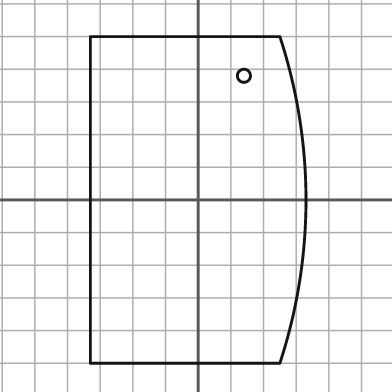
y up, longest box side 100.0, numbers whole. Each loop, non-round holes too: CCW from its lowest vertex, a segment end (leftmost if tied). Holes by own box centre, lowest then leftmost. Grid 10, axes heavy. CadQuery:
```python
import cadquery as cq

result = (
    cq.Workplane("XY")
    .moveTo(-33.0, -50.0)
    .lineTo(25.0, -50.0)
    .threePointArc((33.0, 0.0), (25.0, 50.0))
    .lineTo(-33.0, 50.0)
    .close()
    .moveTo(14.0, 38.0)
    .circle(2.0)
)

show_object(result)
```